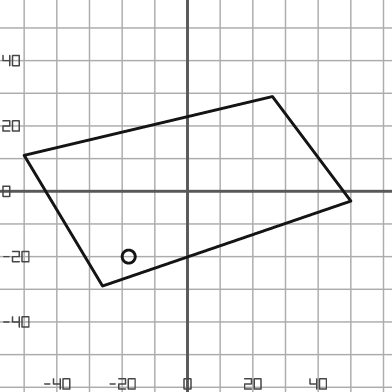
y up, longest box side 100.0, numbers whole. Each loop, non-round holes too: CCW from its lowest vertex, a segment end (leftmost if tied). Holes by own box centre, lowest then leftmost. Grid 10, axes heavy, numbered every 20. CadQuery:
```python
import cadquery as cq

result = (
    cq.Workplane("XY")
    .moveTo(-26.0, -29.0)
    .lineTo(50.0, -3.0)
    .lineTo(26.0, 29.0)
    .lineTo(-50.0, 11.0)
    .close()
    .moveTo(-18.0, -20.0)
    .circle(2.0)
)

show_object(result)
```